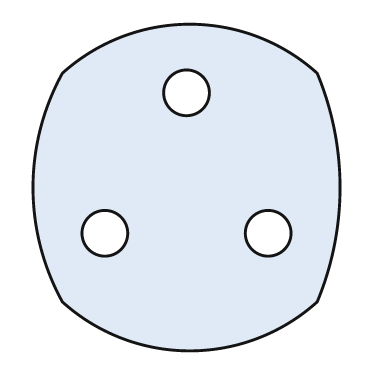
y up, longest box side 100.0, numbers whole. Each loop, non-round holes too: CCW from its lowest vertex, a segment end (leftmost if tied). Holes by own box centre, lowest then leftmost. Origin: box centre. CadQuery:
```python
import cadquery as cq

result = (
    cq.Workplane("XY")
    .moveTo(-38.0, -35.0)
    .threePointArc((1.0, -50.0), (40.0, -35.0))
    .threePointArc((47.0, 0.0), (40.0, 35.0))
    .threePointArc((1.0, 50.0), (-38.0, 35.0))
    .threePointArc((-47.0, 0.0), (-38.0, -35.0))
    .close()
    .moveTo(-25.0, -14.0)
    .circle(7.0)
    .moveTo(25.0, -14.0)
    .circle(7.0)
    .moveTo(0.0, 29.0)
    .circle(7.0)
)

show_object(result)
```